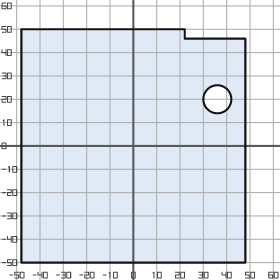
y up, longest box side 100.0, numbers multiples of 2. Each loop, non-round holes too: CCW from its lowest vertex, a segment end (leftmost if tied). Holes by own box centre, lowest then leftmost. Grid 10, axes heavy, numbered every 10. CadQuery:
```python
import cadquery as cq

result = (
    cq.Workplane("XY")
    .moveTo(-48.0, -50.0)
    .lineTo(48.0, -50.0)
    .lineTo(48.0, 46.0)
    .lineTo(22.0, 46.0)
    .lineTo(22.0, 50.0)
    .lineTo(-48.0, 50.0)
    .close()
    .moveTo(36.0, 20.0)
    .circle(6.0)
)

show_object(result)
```